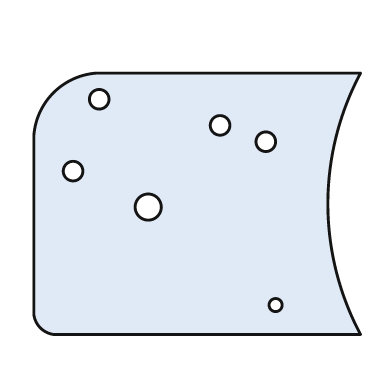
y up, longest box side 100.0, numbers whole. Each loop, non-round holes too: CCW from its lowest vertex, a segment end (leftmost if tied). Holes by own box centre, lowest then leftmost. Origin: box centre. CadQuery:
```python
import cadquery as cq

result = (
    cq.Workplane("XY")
    .moveTo(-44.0, -40.0)
    .lineTo(50.0, -40.0)
    .threePointArc((40.0, 0.0), (50.0, 40.0))
    .lineTo(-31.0, 40.0)
    .threePointArc((-44.0, 34.0), (-50.0, 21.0))
    .lineTo(-50.0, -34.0)
    .threePointArc((-48.0, -38.0), (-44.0, -40.0))
    .close()
    .moveTo(24.0, -31.0)
    .circle(2.0)
    .moveTo(-15.0, -1.0)
    .circle(4.0)
    .moveTo(-38.0, 10.0)
    .circle(3.0)
    .moveTo(21.0, 19.0)
    .circle(3.0)
    .moveTo(7.0, 24.0)
    .circle(3.0)
    .moveTo(-30.0, 32.0)
    .circle(3.0)
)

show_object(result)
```